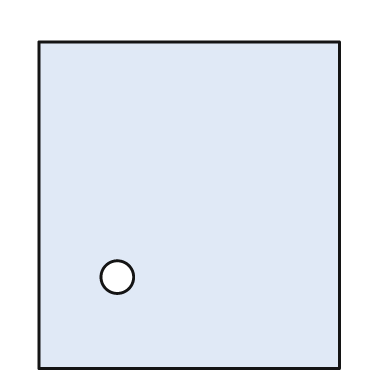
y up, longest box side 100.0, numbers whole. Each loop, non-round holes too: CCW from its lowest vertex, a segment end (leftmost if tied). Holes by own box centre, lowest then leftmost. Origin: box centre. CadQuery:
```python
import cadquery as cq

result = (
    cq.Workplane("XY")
    .moveTo(-46.0, -50.0)
    .lineTo(46.0, -50.0)
    .lineTo(46.0, 50.0)
    .lineTo(-46.0, 50.0)
    .close()
    .moveTo(-22.0, -22.0)
    .circle(5.0)
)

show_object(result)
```